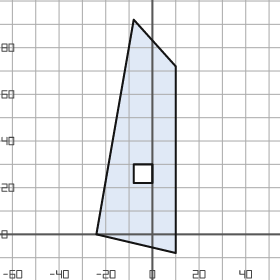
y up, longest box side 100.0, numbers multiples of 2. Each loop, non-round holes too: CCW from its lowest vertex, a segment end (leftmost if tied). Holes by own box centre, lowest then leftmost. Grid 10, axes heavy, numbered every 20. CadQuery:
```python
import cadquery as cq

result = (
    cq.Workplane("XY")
    .moveTo(10.0, -8.0)
    .lineTo(10.0, 72.0)
    .lineTo(-8.0, 92.0)
    .lineTo(-24.0, 0.0)
    .close()
    .moveTo(-8.0, 22.0)
    .lineTo(0.0, 22.0)
    .lineTo(0.0, 30.0)
    .lineTo(-8.0, 30.0)
    .close()
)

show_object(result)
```